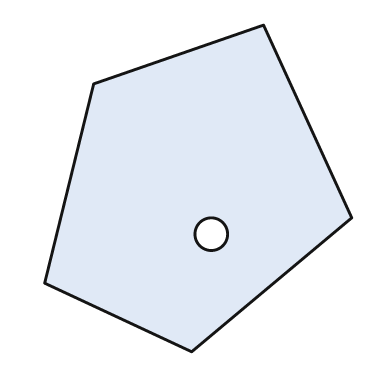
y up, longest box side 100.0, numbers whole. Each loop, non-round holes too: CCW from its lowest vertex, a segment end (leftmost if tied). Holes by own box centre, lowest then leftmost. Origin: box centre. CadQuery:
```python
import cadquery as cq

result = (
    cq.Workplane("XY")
    .moveTo(-2.0, -50.0)
    .lineTo(47.0, -9.0)
    .lineTo(20.0, 50.0)
    .lineTo(-32.0, 32.0)
    .lineTo(-47.0, -29.0)
    .close()
    .moveTo(4.0, -14.0)
    .circle(5.0)
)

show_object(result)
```